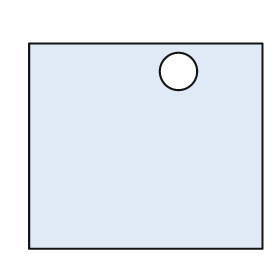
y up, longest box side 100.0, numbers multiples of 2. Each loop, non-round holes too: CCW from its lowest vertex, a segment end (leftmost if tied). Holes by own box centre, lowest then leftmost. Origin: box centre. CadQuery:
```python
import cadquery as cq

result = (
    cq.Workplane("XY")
    .moveTo(-50.0, -44.0)
    .lineTo(50.0, -44.0)
    .lineTo(50.0, 44.0)
    .lineTo(-50.0, 44.0)
    .close()
    .moveTo(14.0, 32.0)
    .circle(8.0)
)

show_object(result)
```